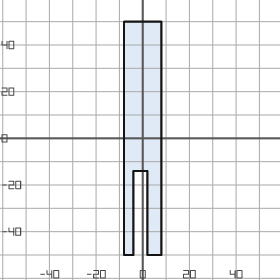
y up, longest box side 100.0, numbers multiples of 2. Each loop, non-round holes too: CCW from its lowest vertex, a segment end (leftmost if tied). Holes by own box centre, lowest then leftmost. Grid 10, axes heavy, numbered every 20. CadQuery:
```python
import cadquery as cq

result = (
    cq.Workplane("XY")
    .moveTo(-8.0, -50.0)
    .lineTo(-4.0, -50.0)
    .lineTo(-4.0, -14.0)
    .lineTo(2.0, -14.0)
    .lineTo(2.0, -50.0)
    .lineTo(8.0, -50.0)
    .lineTo(8.0, 50.0)
    .lineTo(-8.0, 50.0)
    .close()
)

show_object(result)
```